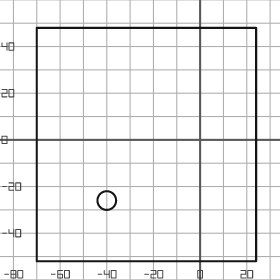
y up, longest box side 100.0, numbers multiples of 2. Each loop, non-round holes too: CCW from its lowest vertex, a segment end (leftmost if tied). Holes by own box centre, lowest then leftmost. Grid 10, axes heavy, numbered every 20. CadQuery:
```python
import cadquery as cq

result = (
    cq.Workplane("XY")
    .moveTo(-70.0, -52.0)
    .lineTo(24.0, -52.0)
    .lineTo(24.0, 48.0)
    .lineTo(-70.0, 48.0)
    .close()
    .moveTo(-40.0, -26.0)
    .circle(4.0)
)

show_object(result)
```